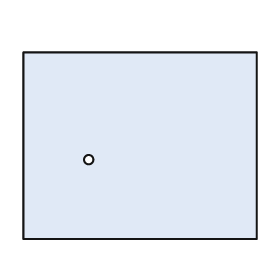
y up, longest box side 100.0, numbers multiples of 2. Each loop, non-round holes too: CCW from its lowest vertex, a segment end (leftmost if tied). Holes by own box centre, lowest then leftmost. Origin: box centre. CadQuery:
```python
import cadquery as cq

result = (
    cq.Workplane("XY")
    .moveTo(-50.0, -40.0)
    .lineTo(50.0, -40.0)
    .lineTo(50.0, 40.0)
    .lineTo(-50.0, 40.0)
    .close()
    .moveTo(-22.0, -6.0)
    .circle(2.0)
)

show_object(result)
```